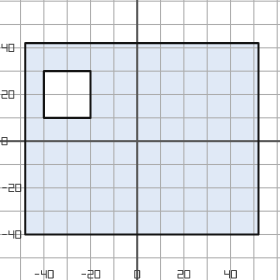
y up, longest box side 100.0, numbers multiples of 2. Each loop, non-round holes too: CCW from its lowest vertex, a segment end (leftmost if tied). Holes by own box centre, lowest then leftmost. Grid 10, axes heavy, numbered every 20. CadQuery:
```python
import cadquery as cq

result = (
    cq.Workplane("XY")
    .moveTo(-48.0, -40.0)
    .lineTo(52.0, -40.0)
    .lineTo(52.0, 42.0)
    .lineTo(-48.0, 42.0)
    .close()
    .moveTo(-40.0, 10.0)
    .lineTo(-20.0, 10.0)
    .lineTo(-20.0, 30.0)
    .lineTo(-40.0, 30.0)
    .close()
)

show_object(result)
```